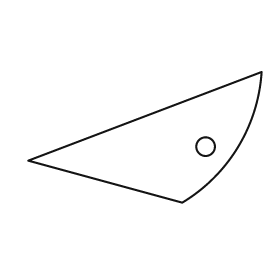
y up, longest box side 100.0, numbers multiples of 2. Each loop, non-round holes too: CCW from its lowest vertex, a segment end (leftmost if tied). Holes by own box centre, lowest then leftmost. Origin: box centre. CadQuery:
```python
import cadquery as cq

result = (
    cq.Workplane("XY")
    .moveTo(16.0, -28.0)
    .threePointArc((40.0, -4.0), (50.0, 28.0))
    .lineTo(-50.0, -10.0)
    .close()
    .moveTo(26.0, -4.0)
    .circle(4.0)
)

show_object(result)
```